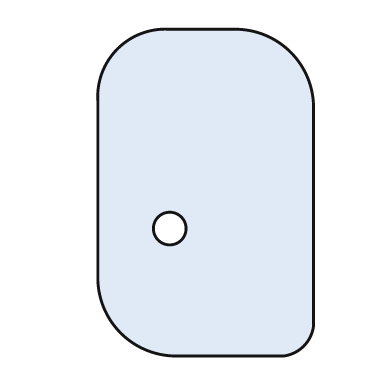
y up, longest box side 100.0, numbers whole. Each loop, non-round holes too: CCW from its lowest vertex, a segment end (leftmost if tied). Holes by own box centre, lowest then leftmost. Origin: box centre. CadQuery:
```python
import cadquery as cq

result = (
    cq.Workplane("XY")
    .moveTo(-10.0, -50.0)
    .lineTo(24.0, -50.0)
    .threePointArc((30.0, -47.0), (33.0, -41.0))
    .lineTo(33.0, 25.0)
    .threePointArc((26.0, 43.0), (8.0, 50.0))
    .lineTo(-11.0, 50.0)
    .threePointArc((-27.0, 44.0), (-33.0, 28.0))
    .lineTo(-33.0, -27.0)
    .threePointArc((-26.0, -43.0), (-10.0, -50.0))
    .close()
    .moveTo(-11.0, -11.0)
    .circle(5.0)
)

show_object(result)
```